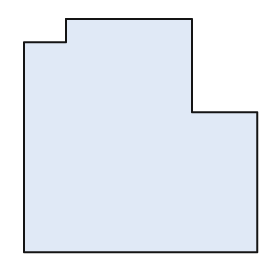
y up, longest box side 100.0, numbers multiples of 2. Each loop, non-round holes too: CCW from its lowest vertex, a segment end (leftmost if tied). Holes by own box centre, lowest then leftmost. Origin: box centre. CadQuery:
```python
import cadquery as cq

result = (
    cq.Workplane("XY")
    .moveTo(-50.0, -50.0)
    .lineTo(50.0, -50.0)
    .lineTo(50.0, 10.0)
    .lineTo(22.0, 10.0)
    .lineTo(22.0, 50.0)
    .lineTo(-32.0, 50.0)
    .lineTo(-32.0, 40.0)
    .lineTo(-50.0, 40.0)
    .close()
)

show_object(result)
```